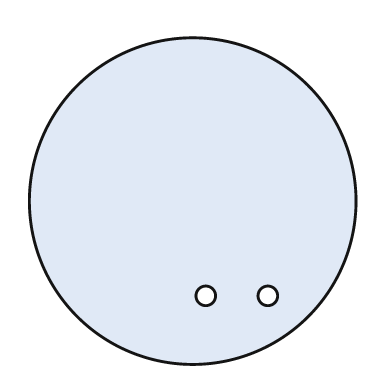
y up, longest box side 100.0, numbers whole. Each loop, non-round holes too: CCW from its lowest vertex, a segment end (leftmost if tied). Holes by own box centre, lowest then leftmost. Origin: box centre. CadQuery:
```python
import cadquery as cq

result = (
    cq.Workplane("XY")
    .moveTo(0.0, 0.0)
    .circle(50.0)
    .moveTo(4.0, -29.0)
    .circle(3.0)
    .moveTo(23.0, -29.0)
    .circle(3.0)
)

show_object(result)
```